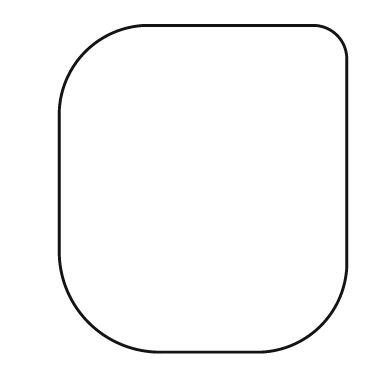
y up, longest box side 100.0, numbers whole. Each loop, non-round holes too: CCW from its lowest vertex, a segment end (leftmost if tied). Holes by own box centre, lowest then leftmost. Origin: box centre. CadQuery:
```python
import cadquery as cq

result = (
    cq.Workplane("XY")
    .moveTo(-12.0, -50.0)
    .lineTo(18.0, -50.0)
    .threePointArc((36.0, -42.0), (44.0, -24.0))
    .lineTo(44.0, 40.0)
    .threePointArc((41.0, 47.0), (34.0, 50.0))
    .lineTo(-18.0, 50.0)
    .threePointArc((-36.0, 42.0), (-44.0, 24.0))
    .lineTo(-44.0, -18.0)
    .threePointArc((-35.0, -41.0), (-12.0, -50.0))
    .close()
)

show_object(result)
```